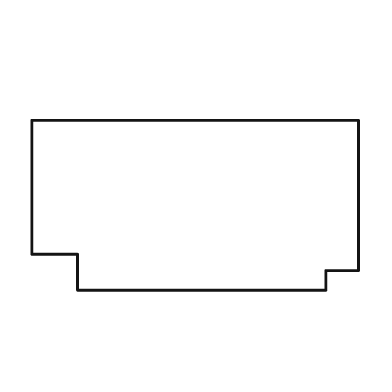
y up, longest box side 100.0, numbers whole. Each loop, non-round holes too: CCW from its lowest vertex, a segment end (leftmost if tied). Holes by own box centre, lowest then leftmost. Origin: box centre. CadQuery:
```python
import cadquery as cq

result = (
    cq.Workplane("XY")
    .moveTo(-36.0, -26.0)
    .lineTo(40.0, -26.0)
    .lineTo(40.0, -20.0)
    .lineTo(50.0, -20.0)
    .lineTo(50.0, 26.0)
    .lineTo(-50.0, 26.0)
    .lineTo(-50.0, -15.0)
    .lineTo(-36.0, -15.0)
    .close()
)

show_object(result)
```